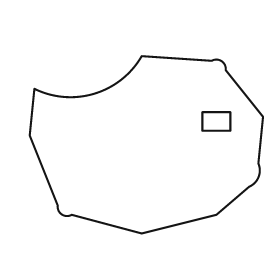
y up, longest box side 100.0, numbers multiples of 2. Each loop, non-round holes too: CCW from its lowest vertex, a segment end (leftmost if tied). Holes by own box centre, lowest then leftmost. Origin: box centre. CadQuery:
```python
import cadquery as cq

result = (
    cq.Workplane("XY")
    .moveTo(-2.0, -38.0)
    .lineTo(30.0, -30.0)
    .lineTo(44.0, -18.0)
    .threePointArc((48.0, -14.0), (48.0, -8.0))
    .lineTo(50.0, 12.0)
    .lineTo(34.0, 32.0)
    .threePointArc((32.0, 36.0), (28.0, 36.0))
    .lineTo(-2.0, 38.0)
    .threePointArc((-22.0, 22.0), (-48.0, 24.0))
    .lineTo(-50.0, 4.0)
    .lineTo(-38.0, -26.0)
    .threePointArc((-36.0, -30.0), (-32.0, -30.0))
    .close()
    .moveTo(24.0, 6.0)
    .lineTo(36.0, 6.0)
    .lineTo(36.0, 14.0)
    .lineTo(24.0, 14.0)
    .close()
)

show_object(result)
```